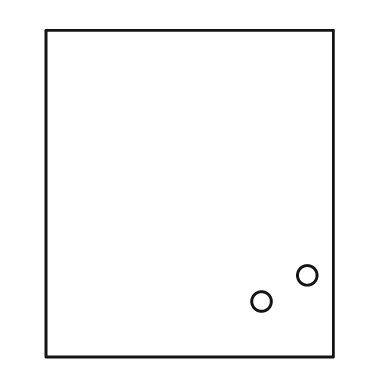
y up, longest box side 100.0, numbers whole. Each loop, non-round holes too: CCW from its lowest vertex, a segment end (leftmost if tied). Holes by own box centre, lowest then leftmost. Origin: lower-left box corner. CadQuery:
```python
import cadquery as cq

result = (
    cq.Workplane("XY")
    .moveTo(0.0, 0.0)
    .lineTo(88.0, 0.0)
    .lineTo(88.0, 100.0)
    .lineTo(0.0, 100.0)
    .close()
    .moveTo(66.0, 17.0)
    .circle(3.0)
    .moveTo(80.0, 25.0)
    .circle(3.0)
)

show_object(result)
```